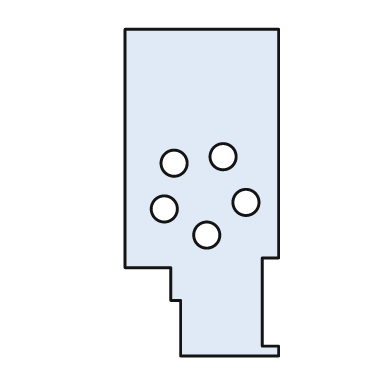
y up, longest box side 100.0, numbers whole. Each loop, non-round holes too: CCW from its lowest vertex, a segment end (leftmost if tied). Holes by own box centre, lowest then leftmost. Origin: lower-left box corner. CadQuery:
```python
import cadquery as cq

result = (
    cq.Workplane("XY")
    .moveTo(17.0, 0.0)
    .lineTo(47.0, 0.0)
    .lineTo(47.0, 3.0)
    .lineTo(42.0, 3.0)
    .lineTo(42.0, 30.0)
    .lineTo(47.0, 30.0)
    .lineTo(47.0, 100.0)
    .lineTo(0.0, 100.0)
    .lineTo(0.0, 27.0)
    .lineTo(14.0, 27.0)
    .lineTo(14.0, 17.0)
    .lineTo(17.0, 17.0)
    .close()
    .moveTo(25.0, 37.0)
    .circle(4.0)
    .moveTo(12.0, 45.0)
    .circle(4.0)
    .moveTo(37.0, 47.0)
    .circle(4.0)
    .moveTo(15.0, 59.0)
    .circle(4.0)
    .moveTo(30.0, 61.0)
    .circle(4.0)
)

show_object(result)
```